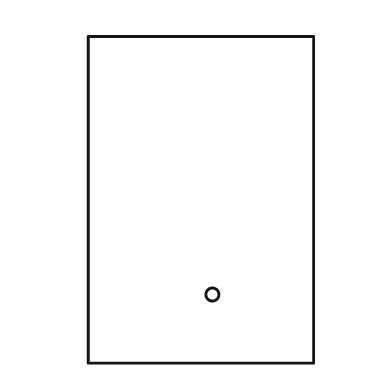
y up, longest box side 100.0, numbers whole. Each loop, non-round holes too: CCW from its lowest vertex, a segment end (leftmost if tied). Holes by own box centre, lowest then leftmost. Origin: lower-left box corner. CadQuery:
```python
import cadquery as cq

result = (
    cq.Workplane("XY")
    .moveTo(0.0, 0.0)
    .lineTo(69.0, 0.0)
    .lineTo(69.0, 100.0)
    .lineTo(0.0, 100.0)
    .close()
    .moveTo(38.0, 21.0)
    .circle(2.0)
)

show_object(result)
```